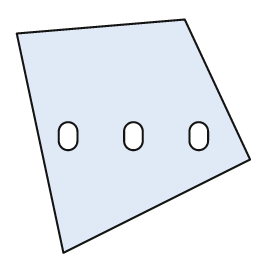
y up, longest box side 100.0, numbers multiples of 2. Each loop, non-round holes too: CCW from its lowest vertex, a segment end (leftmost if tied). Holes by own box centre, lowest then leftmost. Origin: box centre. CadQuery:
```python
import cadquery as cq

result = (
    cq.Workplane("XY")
    .moveTo(-30.0, -50.0)
    .lineTo(50.0, -10.0)
    .lineTo(22.0, 50.0)
    .lineTo(-50.0, 44.0)
    .close()
    .moveTo(-32.0, -2.0)
    .threePointArc((-28.0, -6.0), (-24.0, -2.0))
    .lineTo(-24.0, 2.0)
    .threePointArc((-28.0, 6.0), (-32.0, 2.0))
    .close()
    .moveTo(-4.0, -2.0)
    .threePointArc((0.0, -6.0), (4.0, -2.0))
    .lineTo(4.0, 2.0)
    .threePointArc((0.0, 6.0), (-4.0, 2.0))
    .close()
    .moveTo(24.0, -2.0)
    .threePointArc((28.0, -6.0), (32.0, -2.0))
    .lineTo(32.0, 2.0)
    .threePointArc((28.0, 6.0), (24.0, 2.0))
    .close()
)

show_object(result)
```